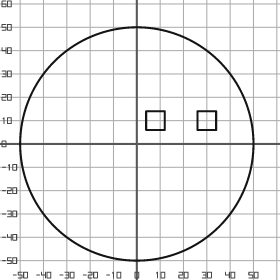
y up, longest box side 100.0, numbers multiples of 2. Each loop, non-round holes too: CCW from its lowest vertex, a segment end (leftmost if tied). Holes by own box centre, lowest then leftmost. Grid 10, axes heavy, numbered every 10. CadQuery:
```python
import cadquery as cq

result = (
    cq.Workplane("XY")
    .moveTo(0.0, 0.0)
    .circle(50.0)
    .moveTo(4.0, 6.0)
    .lineTo(12.0, 6.0)
    .lineTo(12.0, 14.0)
    .lineTo(4.0, 14.0)
    .close()
    .moveTo(26.0, 6.0)
    .lineTo(34.0, 6.0)
    .lineTo(34.0, 14.0)
    .lineTo(26.0, 14.0)
    .close()
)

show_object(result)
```